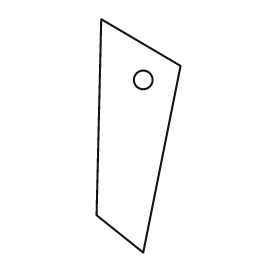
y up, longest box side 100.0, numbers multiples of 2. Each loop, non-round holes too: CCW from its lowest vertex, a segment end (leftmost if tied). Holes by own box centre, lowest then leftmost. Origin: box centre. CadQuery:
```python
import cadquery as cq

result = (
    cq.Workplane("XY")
    .moveTo(2.0, -50.0)
    .lineTo(18.0, 30.0)
    .lineTo(-16.0, 50.0)
    .lineTo(-18.0, -34.0)
    .close()
    .moveTo(2.0, 24.0)
    .circle(4.0)
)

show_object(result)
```